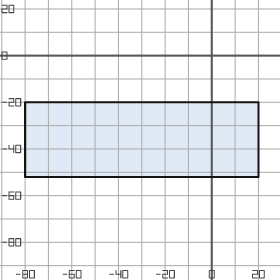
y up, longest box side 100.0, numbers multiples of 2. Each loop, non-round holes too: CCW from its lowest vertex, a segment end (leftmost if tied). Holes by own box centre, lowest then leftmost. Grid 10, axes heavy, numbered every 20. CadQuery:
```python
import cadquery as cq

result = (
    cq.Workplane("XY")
    .moveTo(-80.0, -52.0)
    .lineTo(20.0, -52.0)
    .lineTo(20.0, -20.0)
    .lineTo(-80.0, -20.0)
    .close()
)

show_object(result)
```